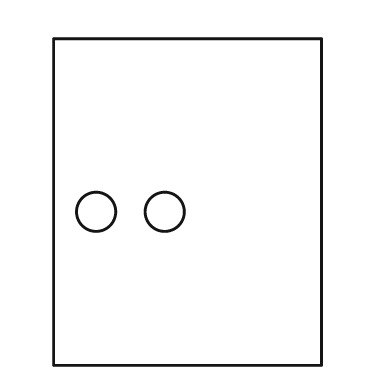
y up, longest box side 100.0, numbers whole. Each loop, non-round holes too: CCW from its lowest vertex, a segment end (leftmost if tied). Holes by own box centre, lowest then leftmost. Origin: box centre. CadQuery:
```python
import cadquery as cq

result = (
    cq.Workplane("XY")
    .moveTo(-41.0, -50.0)
    .lineTo(41.0, -50.0)
    .lineTo(41.0, 50.0)
    .lineTo(-41.0, 50.0)
    .close()
    .moveTo(-28.0, -3.0)
    .circle(6.0)
    .moveTo(-7.0, -3.0)
    .circle(6.0)
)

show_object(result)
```